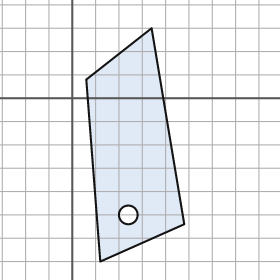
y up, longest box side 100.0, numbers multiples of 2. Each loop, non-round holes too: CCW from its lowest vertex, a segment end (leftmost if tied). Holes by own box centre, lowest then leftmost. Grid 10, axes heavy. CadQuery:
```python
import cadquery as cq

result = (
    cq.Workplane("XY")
    .moveTo(12.0, -70.0)
    .lineTo(48.0, -54.0)
    .lineTo(34.0, 30.0)
    .lineTo(6.0, 8.0)
    .close()
    .moveTo(24.0, -50.0)
    .circle(4.0)
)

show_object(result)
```